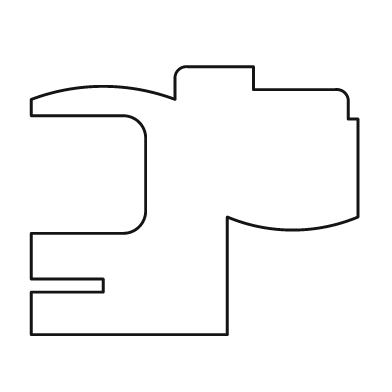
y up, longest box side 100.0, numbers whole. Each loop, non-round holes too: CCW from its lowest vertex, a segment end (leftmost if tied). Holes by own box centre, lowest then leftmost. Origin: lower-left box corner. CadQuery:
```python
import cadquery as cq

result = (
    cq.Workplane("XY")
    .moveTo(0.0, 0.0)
    .lineTo(60.0, 0.0)
    .lineTo(60.0, 36.0)
    .threePointArc((80.0, 32.0), (100.0, 36.0))
    .lineTo(100.0, 66.0)
    .lineTo(97.0, 66.0)
    .lineTo(97.0, 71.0)
    .threePointArc((96.0, 74.0), (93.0, 75.0))
    .lineTo(68.0, 75.0)
    .lineTo(68.0, 82.0)
    .lineTo(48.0, 82.0)
    .threePointArc((45.0, 81.0), (44.0, 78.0))
    .lineTo(44.0, 72.0)
    .threePointArc((22.0, 76.0), (0.0, 72.0))
    .lineTo(0.0, 67.0)
    .lineTo(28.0, 67.0)
    .threePointArc((33.0, 65.0), (35.0, 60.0))
    .lineTo(35.0, 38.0)
    .threePointArc((33.0, 33.0), (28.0, 31.0))
    .lineTo(0.0, 31.0)
    .lineTo(0.0, 17.0)
    .lineTo(22.0, 17.0)
    .lineTo(22.0, 13.0)
    .lineTo(0.0, 13.0)
    .close()
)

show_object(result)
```